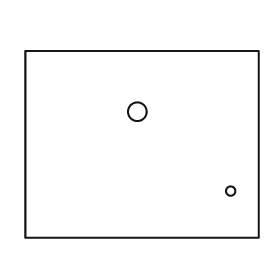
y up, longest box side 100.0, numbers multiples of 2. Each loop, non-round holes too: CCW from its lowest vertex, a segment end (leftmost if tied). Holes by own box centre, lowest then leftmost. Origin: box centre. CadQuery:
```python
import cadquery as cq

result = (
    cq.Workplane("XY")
    .moveTo(-50.0, -40.0)
    .lineTo(50.0, -40.0)
    .lineTo(50.0, 40.0)
    .lineTo(-50.0, 40.0)
    .close()
    .moveTo(38.0, -20.0)
    .circle(2.0)
    .moveTo(-2.0, 14.0)
    .circle(4.0)
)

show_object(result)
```